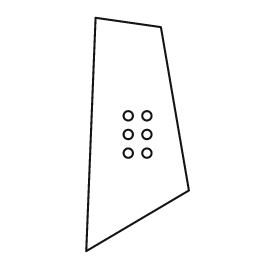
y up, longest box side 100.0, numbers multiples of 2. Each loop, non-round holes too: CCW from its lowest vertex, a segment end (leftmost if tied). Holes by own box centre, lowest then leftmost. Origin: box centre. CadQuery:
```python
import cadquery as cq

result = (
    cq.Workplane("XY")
    .moveTo(-22.0, -50.0)
    .lineTo(22.0, -24.0)
    .lineTo(10.0, 46.0)
    .lineTo(-18.0, 50.0)
    .close()
    .moveTo(-4.0, -8.0)
    .circle(2.0)
    .moveTo(4.0, -8.0)
    .circle(2.0)
    .moveTo(-4.0, 0.0)
    .circle(2.0)
    .moveTo(4.0, 0.0)
    .circle(2.0)
    .moveTo(-4.0, 8.0)
    .circle(2.0)
    .moveTo(4.0, 8.0)
    .circle(2.0)
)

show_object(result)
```